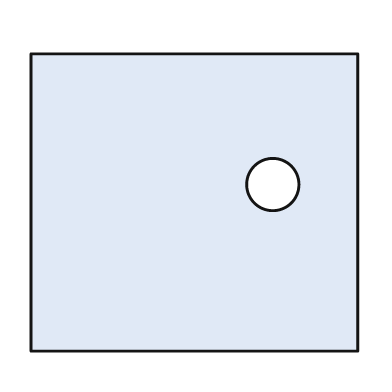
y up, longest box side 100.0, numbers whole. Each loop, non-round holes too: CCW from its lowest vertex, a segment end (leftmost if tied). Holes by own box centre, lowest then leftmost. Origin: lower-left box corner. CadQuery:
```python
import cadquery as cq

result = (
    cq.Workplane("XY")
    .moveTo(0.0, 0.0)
    .lineTo(100.0, 0.0)
    .lineTo(100.0, 91.0)
    .lineTo(0.0, 91.0)
    .close()
    .moveTo(74.0, 51.0)
    .circle(8.0)
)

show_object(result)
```